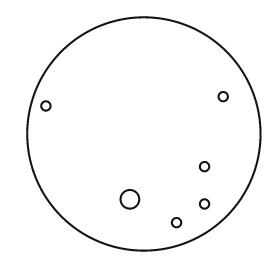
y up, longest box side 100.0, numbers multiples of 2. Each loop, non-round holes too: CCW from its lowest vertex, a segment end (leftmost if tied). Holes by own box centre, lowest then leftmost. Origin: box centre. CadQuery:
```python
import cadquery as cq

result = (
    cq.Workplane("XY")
    .moveTo(0.0, 0.0)
    .circle(50.0)
    .moveTo(14.0, -38.0)
    .circle(2.0)
    .moveTo(26.0, -30.0)
    .circle(2.0)
    .moveTo(-6.0, -28.0)
    .circle(4.0)
    .moveTo(26.0, -14.0)
    .circle(2.0)
    .moveTo(-42.0, 12.0)
    .circle(2.0)
    .moveTo(34.0, 16.0)
    .circle(2.0)
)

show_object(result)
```